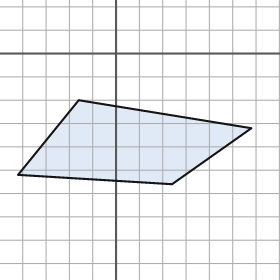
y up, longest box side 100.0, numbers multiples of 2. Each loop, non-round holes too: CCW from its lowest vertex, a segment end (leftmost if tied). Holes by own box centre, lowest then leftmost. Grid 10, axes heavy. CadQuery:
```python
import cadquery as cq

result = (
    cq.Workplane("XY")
    .moveTo(24.0, -56.0)
    .lineTo(58.0, -32.0)
    .lineTo(-16.0, -20.0)
    .lineTo(-42.0, -52.0)
    .close()
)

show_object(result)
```